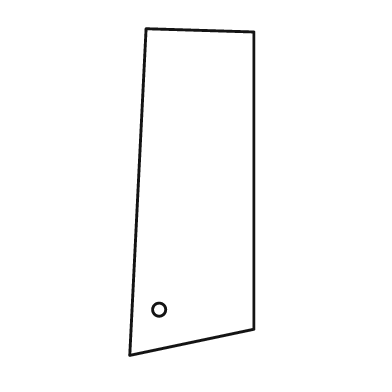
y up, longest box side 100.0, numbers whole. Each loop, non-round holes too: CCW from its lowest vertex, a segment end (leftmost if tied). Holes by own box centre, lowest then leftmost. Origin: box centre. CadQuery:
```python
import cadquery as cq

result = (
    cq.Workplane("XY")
    .moveTo(-19.0, -50.0)
    .lineTo(19.0, -42.0)
    .lineTo(19.0, 49.0)
    .lineTo(-14.0, 50.0)
    .close()
    .moveTo(-10.0, -36.0)
    .circle(2.0)
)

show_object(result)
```